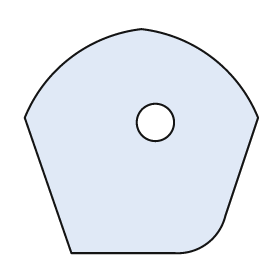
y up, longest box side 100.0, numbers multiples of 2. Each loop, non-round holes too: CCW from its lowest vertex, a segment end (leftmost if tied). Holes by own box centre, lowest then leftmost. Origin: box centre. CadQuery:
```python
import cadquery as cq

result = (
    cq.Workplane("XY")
    .moveTo(-30.0, -48.0)
    .lineTo(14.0, -48.0)
    .threePointArc((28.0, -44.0), (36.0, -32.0))
    .lineTo(50.0, 10.0)
    .threePointArc((30.0, 36.0), (0.0, 48.0))
    .threePointArc((-30.0, 36.0), (-50.0, 10.0))
    .close()
    .moveTo(6.0, 8.0)
    .circle(8.0)
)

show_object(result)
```